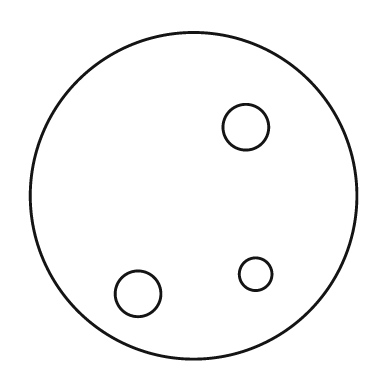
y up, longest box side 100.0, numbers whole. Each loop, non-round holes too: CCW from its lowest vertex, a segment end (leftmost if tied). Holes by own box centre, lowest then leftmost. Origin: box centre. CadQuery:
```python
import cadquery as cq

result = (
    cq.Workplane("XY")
    .moveTo(0.0, 0.0)
    .circle(50.0)
    .moveTo(-17.0, -30.0)
    .circle(7.0)
    .moveTo(19.0, -24.0)
    .circle(5.0)
    .moveTo(16.0, 21.0)
    .circle(7.0)
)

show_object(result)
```